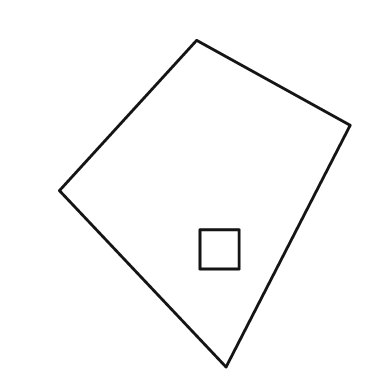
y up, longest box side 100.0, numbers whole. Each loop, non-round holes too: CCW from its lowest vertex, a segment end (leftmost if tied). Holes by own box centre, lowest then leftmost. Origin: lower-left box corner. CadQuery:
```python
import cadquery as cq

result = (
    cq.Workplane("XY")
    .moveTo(51.0, 0.0)
    .lineTo(89.0, 74.0)
    .lineTo(42.0, 100.0)
    .lineTo(0.0, 54.0)
    .close()
    .moveTo(43.0, 30.0)
    .lineTo(55.0, 30.0)
    .lineTo(55.0, 42.0)
    .lineTo(43.0, 42.0)
    .close()
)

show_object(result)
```